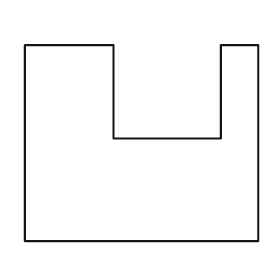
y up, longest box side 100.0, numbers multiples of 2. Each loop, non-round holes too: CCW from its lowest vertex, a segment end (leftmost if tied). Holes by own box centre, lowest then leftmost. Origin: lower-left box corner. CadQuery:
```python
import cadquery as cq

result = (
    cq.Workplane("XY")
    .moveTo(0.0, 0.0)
    .lineTo(100.0, 0.0)
    .lineTo(100.0, 84.0)
    .lineTo(84.0, 84.0)
    .lineTo(84.0, 44.0)
    .lineTo(38.0, 44.0)
    .lineTo(38.0, 84.0)
    .lineTo(0.0, 84.0)
    .close()
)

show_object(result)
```